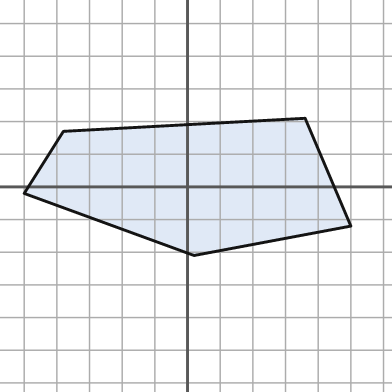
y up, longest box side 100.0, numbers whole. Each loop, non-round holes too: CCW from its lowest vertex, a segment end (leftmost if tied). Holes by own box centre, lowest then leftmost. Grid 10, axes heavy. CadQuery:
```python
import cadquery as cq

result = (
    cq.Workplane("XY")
    .moveTo(2.0, -21.0)
    .lineTo(50.0, -12.0)
    .lineTo(36.0, 21.0)
    .lineTo(-38.0, 17.0)
    .lineTo(-50.0, -2.0)
    .close()
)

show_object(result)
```